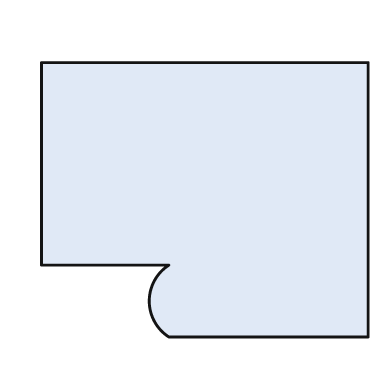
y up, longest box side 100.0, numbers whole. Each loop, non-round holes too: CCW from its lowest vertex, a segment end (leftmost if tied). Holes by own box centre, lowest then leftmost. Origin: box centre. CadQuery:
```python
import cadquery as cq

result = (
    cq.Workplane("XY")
    .moveTo(-11.0, -42.0)
    .lineTo(50.0, -42.0)
    .lineTo(50.0, 42.0)
    .lineTo(-50.0, 42.0)
    .lineTo(-50.0, -20.0)
    .lineTo(-11.0, -20.0)
    .threePointArc((-17.0, -31.0), (-11.0, -42.0))
    .close()
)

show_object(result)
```